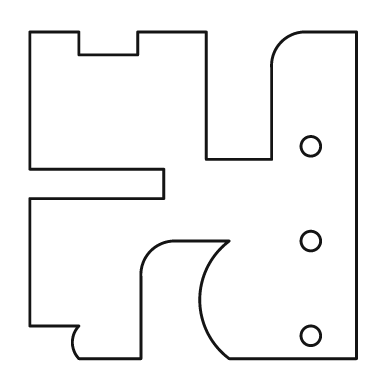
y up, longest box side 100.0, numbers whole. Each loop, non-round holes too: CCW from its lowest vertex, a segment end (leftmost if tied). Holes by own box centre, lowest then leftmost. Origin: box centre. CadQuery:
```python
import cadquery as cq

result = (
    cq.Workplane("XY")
    .moveTo(-35.0, -50.0)
    .lineTo(-16.0, -50.0)
    .lineTo(-16.0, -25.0)
    .threePointArc((-13.0, -17.0), (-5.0, -14.0))
    .lineTo(11.0, -14.0)
    .threePointArc((2.0, -32.0), (11.0, -50.0))
    .lineTo(50.0, -50.0)
    .lineTo(50.0, 50.0)
    .lineTo(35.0, 50.0)
    .threePointArc((27.0, 47.0), (24.0, 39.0))
    .lineTo(24.0, 11.0)
    .lineTo(4.0, 11.0)
    .lineTo(4.0, 50.0)
    .lineTo(-17.0, 50.0)
    .lineTo(-17.0, 43.0)
    .lineTo(-35.0, 43.0)
    .lineTo(-35.0, 50.0)
    .lineTo(-50.0, 50.0)
    .lineTo(-50.0, 8.0)
    .lineTo(-9.0, 8.0)
    .lineTo(-9.0, -1.0)
    .lineTo(-50.0, -1.0)
    .lineTo(-50.0, -40.0)
    .lineTo(-35.0, -40.0)
    .threePointArc((-37.0, -45.0), (-35.0, -50.0))
    .close()
    .moveTo(36.0, -43.0)
    .circle(3.0)
    .moveTo(36.0, -14.0)
    .circle(3.0)
    .moveTo(36.0, 15.0)
    .circle(3.0)
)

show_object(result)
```